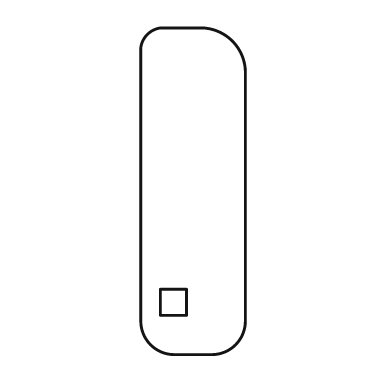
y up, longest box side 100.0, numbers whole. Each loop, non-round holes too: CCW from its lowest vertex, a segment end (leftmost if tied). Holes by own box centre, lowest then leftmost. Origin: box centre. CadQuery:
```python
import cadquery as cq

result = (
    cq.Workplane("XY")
    .moveTo(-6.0, -50.0)
    .lineTo(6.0, -50.0)
    .threePointArc((13.0, -47.0), (16.0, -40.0))
    .lineTo(16.0, 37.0)
    .threePointArc((12.0, 46.0), (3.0, 50.0))
    .lineTo(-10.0, 50.0)
    .threePointArc((-14.0, 48.0), (-16.0, 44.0))
    .lineTo(-16.0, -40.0)
    .threePointArc((-13.0, -47.0), (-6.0, -50.0))
    .close()
    .moveTo(-10.0, -38.0)
    .lineTo(-2.0, -38.0)
    .lineTo(-2.0, -30.0)
    .lineTo(-10.0, -30.0)
    .close()
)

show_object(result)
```